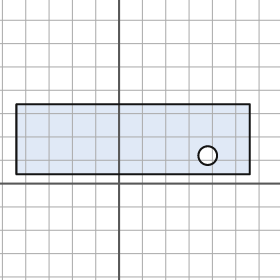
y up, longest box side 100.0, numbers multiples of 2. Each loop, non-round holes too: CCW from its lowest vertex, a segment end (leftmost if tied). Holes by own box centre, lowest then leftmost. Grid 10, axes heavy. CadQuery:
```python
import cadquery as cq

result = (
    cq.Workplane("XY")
    .moveTo(-44.0, 4.0)
    .lineTo(56.0, 4.0)
    .lineTo(56.0, 34.0)
    .lineTo(-44.0, 34.0)
    .close()
    .moveTo(38.0, 12.0)
    .circle(4.0)
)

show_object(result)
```